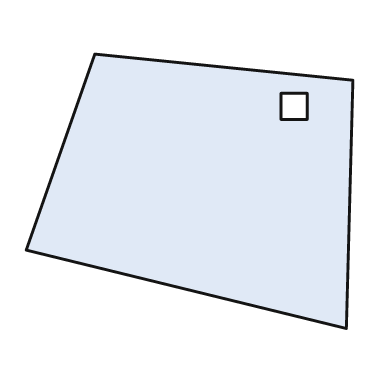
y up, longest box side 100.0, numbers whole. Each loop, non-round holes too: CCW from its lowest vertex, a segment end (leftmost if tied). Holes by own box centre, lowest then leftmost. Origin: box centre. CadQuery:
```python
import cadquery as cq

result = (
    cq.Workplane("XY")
    .moveTo(48.0, -42.0)
    .lineTo(50.0, 34.0)
    .lineTo(-29.0, 42.0)
    .lineTo(-50.0, -18.0)
    .close()
    .moveTo(28.0, 22.0)
    .lineTo(36.0, 22.0)
    .lineTo(36.0, 30.0)
    .lineTo(28.0, 30.0)
    .close()
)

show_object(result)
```